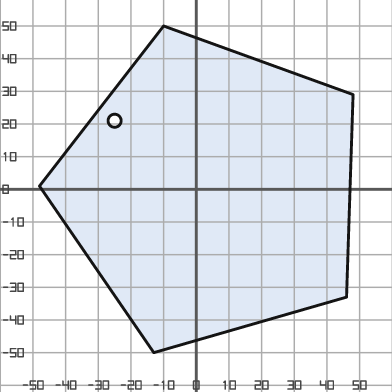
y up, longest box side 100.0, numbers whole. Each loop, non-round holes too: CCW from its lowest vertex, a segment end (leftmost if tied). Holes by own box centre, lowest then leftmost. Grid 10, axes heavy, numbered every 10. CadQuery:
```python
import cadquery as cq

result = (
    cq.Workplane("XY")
    .moveTo(-13.0, -50.0)
    .lineTo(46.0, -33.0)
    .lineTo(48.0, 29.0)
    .lineTo(-10.0, 50.0)
    .lineTo(-48.0, 1.0)
    .close()
    .moveTo(-25.0, 21.0)
    .circle(2.0)
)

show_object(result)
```